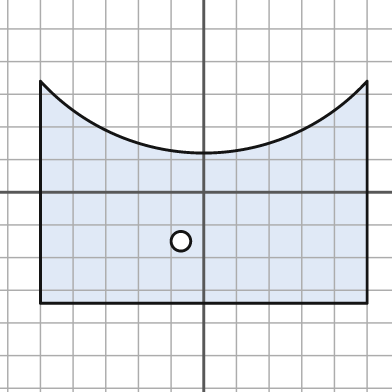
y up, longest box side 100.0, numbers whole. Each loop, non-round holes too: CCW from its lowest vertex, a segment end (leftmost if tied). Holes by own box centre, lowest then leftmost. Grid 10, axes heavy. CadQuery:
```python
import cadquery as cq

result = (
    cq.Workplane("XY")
    .moveTo(-50.0, -34.0)
    .lineTo(50.0, -34.0)
    .lineTo(50.0, 34.0)
    .threePointArc((0.0, 12.0), (-50.0, 34.0))
    .close()
    .moveTo(-7.0, -15.0)
    .circle(3.0)
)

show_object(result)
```